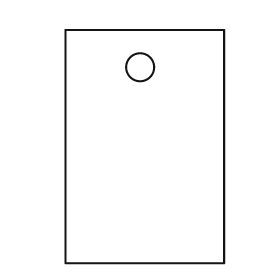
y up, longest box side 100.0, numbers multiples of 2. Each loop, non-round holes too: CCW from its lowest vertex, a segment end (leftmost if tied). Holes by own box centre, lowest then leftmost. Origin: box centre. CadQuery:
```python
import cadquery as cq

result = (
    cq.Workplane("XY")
    .moveTo(-34.0, -50.0)
    .lineTo(34.0, -50.0)
    .lineTo(34.0, 50.0)
    .lineTo(-34.0, 50.0)
    .close()
    .moveTo(-2.0, 34.0)
    .circle(6.0)
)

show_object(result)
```